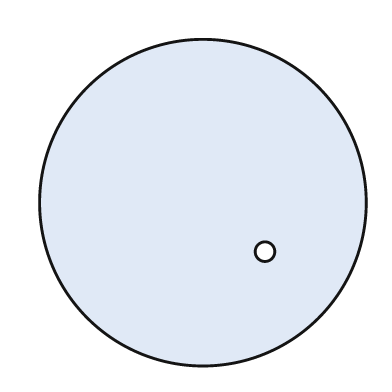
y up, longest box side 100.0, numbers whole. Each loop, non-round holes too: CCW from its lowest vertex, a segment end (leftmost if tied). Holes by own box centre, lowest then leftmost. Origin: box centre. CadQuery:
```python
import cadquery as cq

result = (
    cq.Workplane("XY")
    .moveTo(0.0, 0.0)
    .circle(50.0)
    .moveTo(19.0, -15.0)
    .circle(3.0)
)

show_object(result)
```